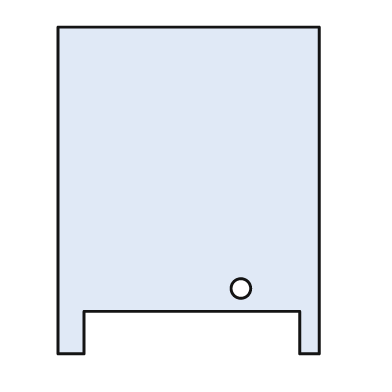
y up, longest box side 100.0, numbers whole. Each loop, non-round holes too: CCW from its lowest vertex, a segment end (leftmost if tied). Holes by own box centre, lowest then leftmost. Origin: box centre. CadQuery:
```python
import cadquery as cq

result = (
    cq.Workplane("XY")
    .moveTo(-40.0, -50.0)
    .lineTo(-32.0, -50.0)
    .lineTo(-32.0, -37.0)
    .lineTo(34.0, -37.0)
    .lineTo(34.0, -50.0)
    .lineTo(40.0, -50.0)
    .lineTo(40.0, 50.0)
    .lineTo(-40.0, 50.0)
    .close()
    .moveTo(16.0, -30.0)
    .circle(3.0)
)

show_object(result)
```